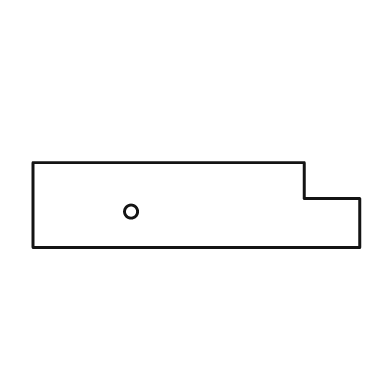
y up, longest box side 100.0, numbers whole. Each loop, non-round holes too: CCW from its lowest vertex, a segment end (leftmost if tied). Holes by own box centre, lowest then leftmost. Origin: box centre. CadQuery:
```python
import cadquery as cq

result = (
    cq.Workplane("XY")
    .moveTo(-50.0, -13.0)
    .lineTo(50.0, -13.0)
    .lineTo(50.0, 2.0)
    .lineTo(33.0, 2.0)
    .lineTo(33.0, 13.0)
    .lineTo(-50.0, 13.0)
    .close()
    .moveTo(-20.0, -2.0)
    .circle(2.0)
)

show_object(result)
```